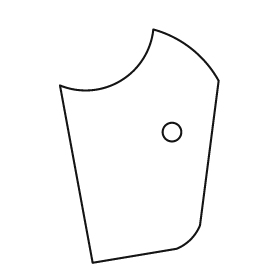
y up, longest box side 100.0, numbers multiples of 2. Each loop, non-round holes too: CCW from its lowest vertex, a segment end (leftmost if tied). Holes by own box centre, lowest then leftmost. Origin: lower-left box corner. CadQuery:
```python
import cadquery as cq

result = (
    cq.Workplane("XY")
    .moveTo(14.0, 0.0)
    .lineTo(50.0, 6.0)
    .threePointArc((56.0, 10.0), (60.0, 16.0))
    .lineTo(68.0, 78.0)
    .threePointArc((56.0, 92.0), (40.0, 100.0))
    .threePointArc((26.0, 78.0), (0.0, 76.0))
    .close()
    .moveTo(48.0, 56.0)
    .circle(4.0)
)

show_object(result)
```